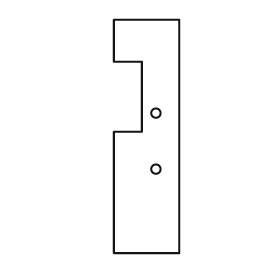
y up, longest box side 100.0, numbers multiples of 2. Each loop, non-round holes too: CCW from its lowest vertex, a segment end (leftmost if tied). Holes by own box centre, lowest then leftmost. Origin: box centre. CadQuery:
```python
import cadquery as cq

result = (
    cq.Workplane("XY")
    .moveTo(-14.0, -50.0)
    .lineTo(14.0, -50.0)
    .lineTo(14.0, 50.0)
    .lineTo(-14.0, 50.0)
    .lineTo(-14.0, 32.0)
    .lineTo(-2.0, 32.0)
    .lineTo(-2.0, 2.0)
    .lineTo(-14.0, 2.0)
    .close()
    .moveTo(4.0, -14.0)
    .circle(2.0)
    .moveTo(4.0, 10.0)
    .circle(2.0)
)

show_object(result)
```